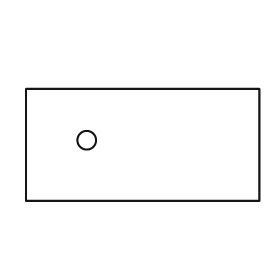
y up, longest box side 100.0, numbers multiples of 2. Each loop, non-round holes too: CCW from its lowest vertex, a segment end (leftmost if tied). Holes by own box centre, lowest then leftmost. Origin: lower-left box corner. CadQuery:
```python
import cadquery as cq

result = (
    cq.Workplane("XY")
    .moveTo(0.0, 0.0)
    .lineTo(100.0, 0.0)
    .lineTo(100.0, 48.0)
    .lineTo(0.0, 48.0)
    .close()
    .moveTo(26.0, 26.0)
    .circle(4.0)
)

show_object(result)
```